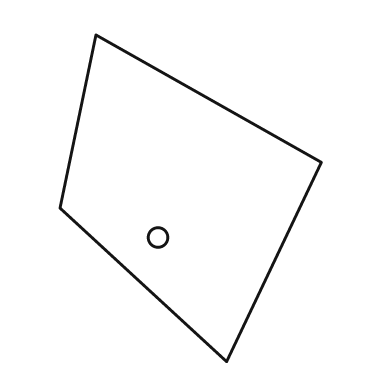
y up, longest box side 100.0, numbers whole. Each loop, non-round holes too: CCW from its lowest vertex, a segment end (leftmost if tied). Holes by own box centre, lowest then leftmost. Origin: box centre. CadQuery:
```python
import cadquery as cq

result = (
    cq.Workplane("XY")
    .moveTo(11.0, -50.0)
    .lineTo(40.0, 11.0)
    .lineTo(-29.0, 50.0)
    .lineTo(-40.0, -3.0)
    .close()
    .moveTo(-10.0, -12.0)
    .circle(3.0)
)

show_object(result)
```